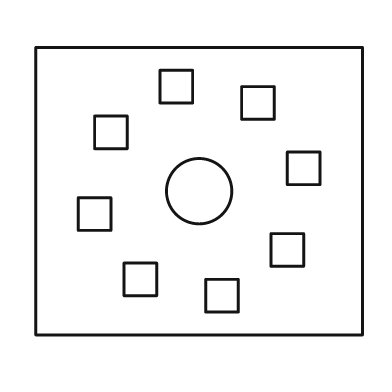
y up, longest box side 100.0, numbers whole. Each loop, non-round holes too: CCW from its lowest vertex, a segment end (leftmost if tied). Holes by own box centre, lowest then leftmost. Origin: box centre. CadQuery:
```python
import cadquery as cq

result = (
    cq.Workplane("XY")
    .moveTo(-50.0, -44.0)
    .lineTo(50.0, -44.0)
    .lineTo(50.0, 44.0)
    .lineTo(-50.0, 44.0)
    .close()
    .moveTo(2.0, -37.0)
    .lineTo(12.0, -37.0)
    .lineTo(12.0, -27.0)
    .lineTo(2.0, -27.0)
    .close()
    .moveTo(-23.0, -32.0)
    .lineTo(-13.0, -32.0)
    .lineTo(-13.0, -22.0)
    .lineTo(-23.0, -22.0)
    .close()
    .moveTo(22.0, -23.0)
    .lineTo(32.0, -23.0)
    .lineTo(32.0, -13.0)
    .lineTo(22.0, -13.0)
    .close()
    .moveTo(-37.0, -12.0)
    .lineTo(-27.0, -12.0)
    .lineTo(-27.0, -2.0)
    .lineTo(-37.0, -2.0)
    .close()
    .moveTo(0.0, 0.0)
    .circle(10.0)
    .moveTo(27.0, 2.0)
    .lineTo(37.0, 2.0)
    .lineTo(37.0, 12.0)
    .lineTo(27.0, 12.0)
    .close()
    .moveTo(-32.0, 13.0)
    .lineTo(-22.0, 13.0)
    .lineTo(-22.0, 23.0)
    .lineTo(-32.0, 23.0)
    .close()
    .moveTo(13.0, 22.0)
    .lineTo(23.0, 22.0)
    .lineTo(23.0, 32.0)
    .lineTo(13.0, 32.0)
    .close()
    .moveTo(-12.0, 27.0)
    .lineTo(-2.0, 27.0)
    .lineTo(-2.0, 37.0)
    .lineTo(-12.0, 37.0)
    .close()
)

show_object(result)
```